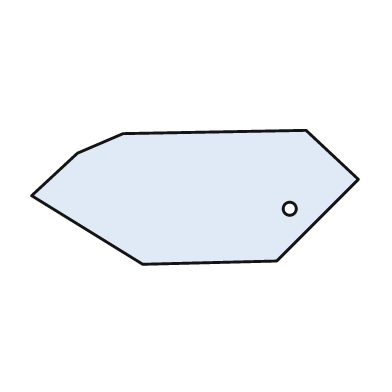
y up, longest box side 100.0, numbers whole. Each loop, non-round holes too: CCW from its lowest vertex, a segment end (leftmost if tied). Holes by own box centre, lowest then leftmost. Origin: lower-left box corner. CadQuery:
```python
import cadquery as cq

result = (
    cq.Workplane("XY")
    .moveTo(34.0, 0.0)
    .lineTo(75.0, 1.0)
    .lineTo(100.0, 26.0)
    .lineTo(84.0, 41.0)
    .lineTo(28.0, 40.0)
    .lineTo(14.0, 34.0)
    .lineTo(0.0, 21.0)
    .close()
    .moveTo(79.0, 17.0)
    .circle(2.0)
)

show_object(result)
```